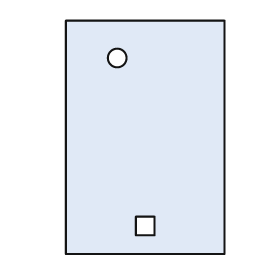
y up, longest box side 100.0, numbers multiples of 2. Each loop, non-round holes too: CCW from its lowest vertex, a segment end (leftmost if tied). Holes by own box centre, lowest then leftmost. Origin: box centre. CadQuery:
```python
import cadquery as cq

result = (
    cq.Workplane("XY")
    .moveTo(-34.0, -50.0)
    .lineTo(34.0, -50.0)
    .lineTo(34.0, 50.0)
    .lineTo(-34.0, 50.0)
    .close()
    .moveTo(-4.0, -42.0)
    .lineTo(4.0, -42.0)
    .lineTo(4.0, -34.0)
    .lineTo(-4.0, -34.0)
    .close()
    .moveTo(-12.0, 34.0)
    .circle(4.0)
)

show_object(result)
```